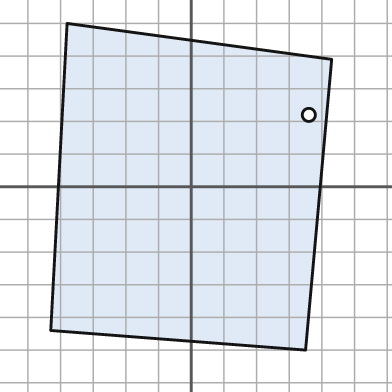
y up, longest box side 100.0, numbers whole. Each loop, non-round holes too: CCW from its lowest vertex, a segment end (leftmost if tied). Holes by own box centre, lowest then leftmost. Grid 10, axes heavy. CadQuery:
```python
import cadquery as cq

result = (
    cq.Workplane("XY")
    .moveTo(35.0, -50.0)
    .lineTo(43.0, 39.0)
    .lineTo(-38.0, 50.0)
    .lineTo(-43.0, -44.0)
    .close()
    .moveTo(36.0, 22.0)
    .circle(2.0)
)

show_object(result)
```